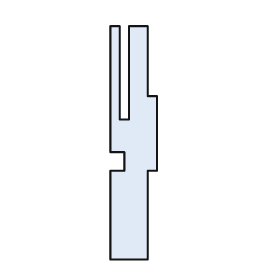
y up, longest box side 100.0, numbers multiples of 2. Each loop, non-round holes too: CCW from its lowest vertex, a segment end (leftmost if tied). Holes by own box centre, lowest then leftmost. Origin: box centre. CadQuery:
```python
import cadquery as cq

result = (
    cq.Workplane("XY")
    .moveTo(-10.0, -50.0)
    .lineTo(6.0, -50.0)
    .lineTo(6.0, -12.0)
    .lineTo(10.0, -12.0)
    .lineTo(10.0, 20.0)
    .lineTo(6.0, 20.0)
    .lineTo(6.0, 50.0)
    .lineTo(-2.0, 50.0)
    .lineTo(-2.0, 10.0)
    .lineTo(-6.0, 10.0)
    .lineTo(-6.0, 50.0)
    .lineTo(-10.0, 50.0)
    .lineTo(-10.0, -4.0)
    .lineTo(-4.0, -4.0)
    .lineTo(-4.0, -12.0)
    .lineTo(-10.0, -12.0)
    .close()
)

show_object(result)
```